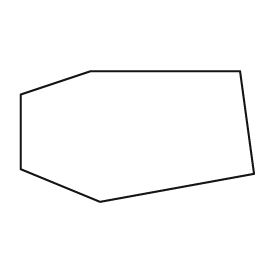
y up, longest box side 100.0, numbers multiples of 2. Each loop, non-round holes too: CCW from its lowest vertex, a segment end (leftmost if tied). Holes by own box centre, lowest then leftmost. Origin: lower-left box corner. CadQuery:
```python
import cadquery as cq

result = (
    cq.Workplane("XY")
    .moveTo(34.0, 0.0)
    .lineTo(100.0, 12.0)
    .lineTo(94.0, 56.0)
    .lineTo(30.0, 56.0)
    .lineTo(0.0, 46.0)
    .lineTo(0.0, 14.0)
    .close()
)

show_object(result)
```